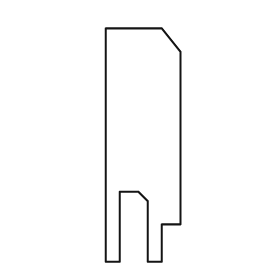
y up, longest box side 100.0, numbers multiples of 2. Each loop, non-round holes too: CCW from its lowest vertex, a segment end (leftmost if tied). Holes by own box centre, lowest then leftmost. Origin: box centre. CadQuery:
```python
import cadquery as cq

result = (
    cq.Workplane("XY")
    .moveTo(-16.0, -50.0)
    .lineTo(-10.0, -50.0)
    .lineTo(-10.0, -20.0)
    .lineTo(-2.0, -20.0)
    .lineTo(2.0, -24.0)
    .lineTo(2.0, -50.0)
    .lineTo(8.0, -50.0)
    .lineTo(8.0, -34.0)
    .lineTo(16.0, -34.0)
    .lineTo(16.0, 40.0)
    .lineTo(8.0, 50.0)
    .lineTo(-16.0, 50.0)
    .close()
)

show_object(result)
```